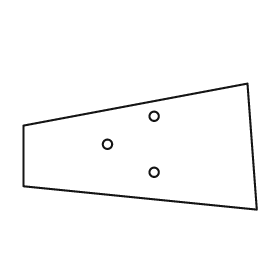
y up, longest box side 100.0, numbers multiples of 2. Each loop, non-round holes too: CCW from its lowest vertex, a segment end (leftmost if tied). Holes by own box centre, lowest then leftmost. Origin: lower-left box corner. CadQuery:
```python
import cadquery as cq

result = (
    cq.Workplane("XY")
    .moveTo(100.0, 0.0)
    .lineTo(96.0, 54.0)
    .lineTo(0.0, 36.0)
    .lineTo(0.0, 10.0)
    .close()
    .moveTo(56.0, 16.0)
    .circle(2.0)
    .moveTo(36.0, 28.0)
    .circle(2.0)
    .moveTo(56.0, 40.0)
    .circle(2.0)
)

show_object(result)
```